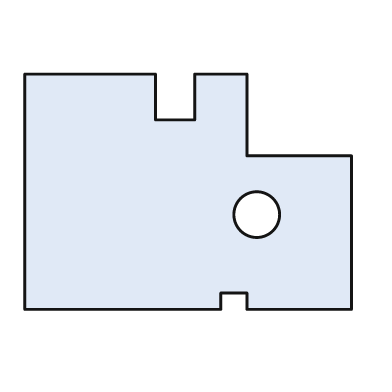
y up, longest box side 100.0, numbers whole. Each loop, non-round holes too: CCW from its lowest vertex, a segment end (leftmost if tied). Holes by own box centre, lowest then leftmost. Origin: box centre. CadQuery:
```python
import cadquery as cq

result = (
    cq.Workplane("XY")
    .moveTo(-50.0, -36.0)
    .lineTo(10.0, -36.0)
    .lineTo(10.0, -31.0)
    .lineTo(18.0, -31.0)
    .lineTo(18.0, -36.0)
    .lineTo(50.0, -36.0)
    .lineTo(50.0, 11.0)
    .lineTo(18.0, 11.0)
    .lineTo(18.0, 36.0)
    .lineTo(2.0, 36.0)
    .lineTo(2.0, 22.0)
    .lineTo(-10.0, 22.0)
    .lineTo(-10.0, 36.0)
    .lineTo(-50.0, 36.0)
    .close()
    .moveTo(21.0, -7.0)
    .circle(7.0)
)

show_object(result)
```